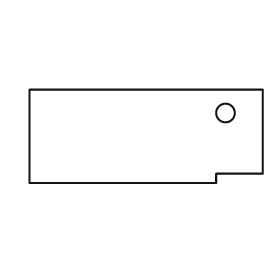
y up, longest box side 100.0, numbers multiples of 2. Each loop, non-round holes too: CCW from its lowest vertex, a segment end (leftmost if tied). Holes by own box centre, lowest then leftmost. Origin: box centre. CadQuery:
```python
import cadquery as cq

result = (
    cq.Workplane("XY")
    .moveTo(-50.0, -20.0)
    .lineTo(30.0, -20.0)
    .lineTo(30.0, -16.0)
    .lineTo(50.0, -16.0)
    .lineTo(50.0, 20.0)
    .lineTo(-50.0, 20.0)
    .close()
    .moveTo(34.0, 10.0)
    .circle(4.0)
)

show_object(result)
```